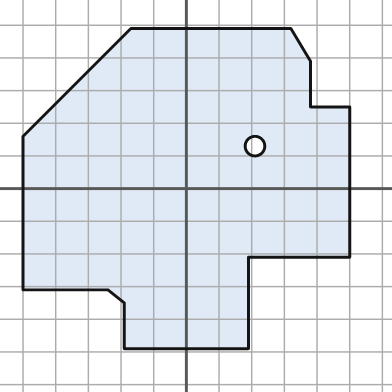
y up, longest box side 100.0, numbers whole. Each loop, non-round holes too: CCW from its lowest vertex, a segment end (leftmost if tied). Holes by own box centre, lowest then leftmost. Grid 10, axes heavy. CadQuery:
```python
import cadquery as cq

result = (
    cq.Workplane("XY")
    .moveTo(-19.0, -49.0)
    .lineTo(19.0, -49.0)
    .lineTo(19.0, -21.0)
    .lineTo(50.0, -21.0)
    .lineTo(50.0, 25.0)
    .lineTo(38.0, 25.0)
    .lineTo(38.0, 39.0)
    .lineTo(32.0, 49.0)
    .lineTo(-17.0, 49.0)
    .lineTo(-50.0, 16.0)
    .lineTo(-50.0, -31.0)
    .lineTo(-24.0, -31.0)
    .lineTo(-19.0, -35.0)
    .close()
    .moveTo(21.0, 13.0)
    .circle(3.0)
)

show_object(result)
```